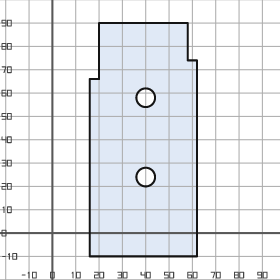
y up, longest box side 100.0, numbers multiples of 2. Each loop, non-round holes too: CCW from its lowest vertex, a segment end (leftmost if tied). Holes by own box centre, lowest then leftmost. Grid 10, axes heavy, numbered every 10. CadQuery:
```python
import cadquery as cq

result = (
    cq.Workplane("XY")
    .moveTo(16.0, -10.0)
    .lineTo(62.0, -10.0)
    .lineTo(62.0, 74.0)
    .lineTo(58.0, 74.0)
    .lineTo(58.0, 90.0)
    .lineTo(20.0, 90.0)
    .lineTo(20.0, 66.0)
    .lineTo(16.0, 66.0)
    .close()
    .moveTo(40.0, 24.0)
    .circle(4.0)
    .moveTo(40.0, 58.0)
    .circle(4.0)
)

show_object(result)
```